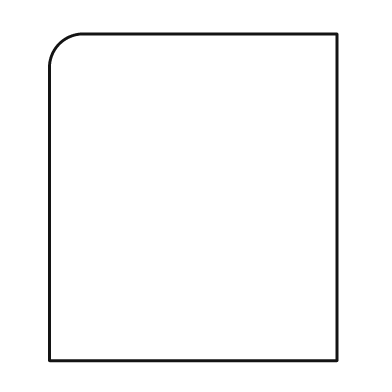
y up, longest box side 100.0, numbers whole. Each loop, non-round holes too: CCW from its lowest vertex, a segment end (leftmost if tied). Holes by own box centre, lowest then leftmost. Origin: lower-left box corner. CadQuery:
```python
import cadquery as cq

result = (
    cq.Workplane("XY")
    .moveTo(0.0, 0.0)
    .lineTo(88.0, 0.0)
    .lineTo(88.0, 100.0)
    .lineTo(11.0, 100.0)
    .threePointArc((3.0, 97.0), (0.0, 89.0))
    .close()
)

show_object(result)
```